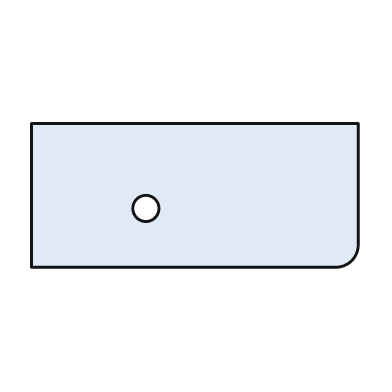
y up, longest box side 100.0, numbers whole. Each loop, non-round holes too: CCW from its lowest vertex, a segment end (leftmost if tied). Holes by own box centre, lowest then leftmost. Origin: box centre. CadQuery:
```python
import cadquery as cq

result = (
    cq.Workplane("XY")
    .moveTo(-50.0, -22.0)
    .lineTo(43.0, -22.0)
    .threePointArc((48.0, -20.0), (50.0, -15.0))
    .lineTo(50.0, 22.0)
    .lineTo(-50.0, 22.0)
    .close()
    .moveTo(-15.0, -4.0)
    .circle(4.0)
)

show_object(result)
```